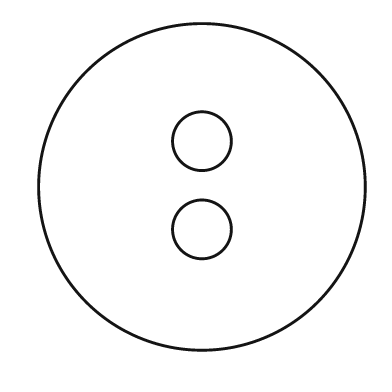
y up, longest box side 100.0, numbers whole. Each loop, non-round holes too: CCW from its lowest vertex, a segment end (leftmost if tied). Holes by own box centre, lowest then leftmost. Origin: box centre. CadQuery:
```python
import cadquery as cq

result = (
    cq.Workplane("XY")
    .moveTo(0.0, 0.0)
    .circle(50.0)
    .moveTo(0.0, -13.0)
    .circle(9.0)
    .moveTo(0.0, 14.0)
    .circle(9.0)
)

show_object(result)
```